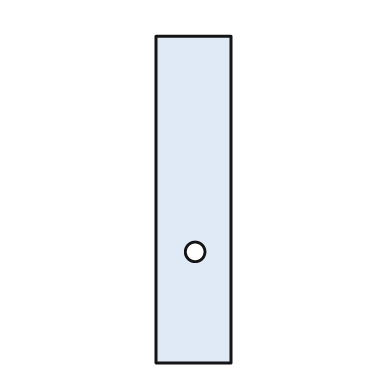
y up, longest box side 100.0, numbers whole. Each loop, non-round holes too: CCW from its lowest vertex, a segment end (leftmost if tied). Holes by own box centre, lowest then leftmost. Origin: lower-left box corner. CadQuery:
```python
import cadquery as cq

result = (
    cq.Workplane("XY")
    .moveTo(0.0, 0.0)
    .lineTo(23.0, 0.0)
    .lineTo(23.0, 100.0)
    .lineTo(0.0, 100.0)
    .close()
    .moveTo(12.0, 34.0)
    .circle(3.0)
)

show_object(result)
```